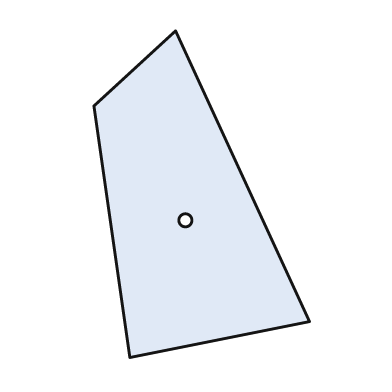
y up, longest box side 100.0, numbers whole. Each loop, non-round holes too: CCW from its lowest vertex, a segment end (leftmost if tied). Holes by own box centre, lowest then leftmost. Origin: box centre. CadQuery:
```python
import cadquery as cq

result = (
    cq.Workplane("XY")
    .moveTo(-22.0, -50.0)
    .lineTo(33.0, -39.0)
    .lineTo(-8.0, 50.0)
    .lineTo(-33.0, 27.0)
    .close()
    .moveTo(-5.0, -8.0)
    .circle(2.0)
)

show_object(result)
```